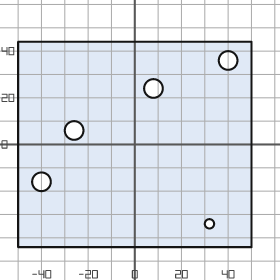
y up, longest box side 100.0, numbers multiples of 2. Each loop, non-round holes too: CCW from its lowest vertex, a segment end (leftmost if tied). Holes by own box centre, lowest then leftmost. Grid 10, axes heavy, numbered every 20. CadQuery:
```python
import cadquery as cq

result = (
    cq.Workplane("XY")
    .moveTo(-50.0, -44.0)
    .lineTo(50.0, -44.0)
    .lineTo(50.0, 44.0)
    .lineTo(-50.0, 44.0)
    .close()
    .moveTo(32.0, -34.0)
    .circle(2.0)
    .moveTo(-40.0, -16.0)
    .circle(4.0)
    .moveTo(-26.0, 6.0)
    .circle(4.0)
    .moveTo(8.0, 24.0)
    .circle(4.0)
    .moveTo(40.0, 36.0)
    .circle(4.0)
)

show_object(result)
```